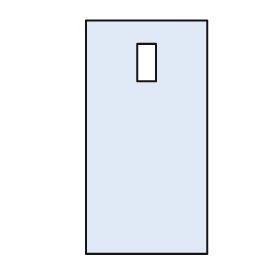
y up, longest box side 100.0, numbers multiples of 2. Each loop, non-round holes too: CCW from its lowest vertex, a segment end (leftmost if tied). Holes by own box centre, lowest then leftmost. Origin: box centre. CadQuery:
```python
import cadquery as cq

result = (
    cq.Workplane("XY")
    .moveTo(-26.0, -50.0)
    .lineTo(26.0, -50.0)
    .lineTo(26.0, 50.0)
    .lineTo(-26.0, 50.0)
    .close()
    .moveTo(-4.0, 24.0)
    .lineTo(4.0, 24.0)
    .lineTo(4.0, 40.0)
    .lineTo(-4.0, 40.0)
    .close()
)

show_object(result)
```